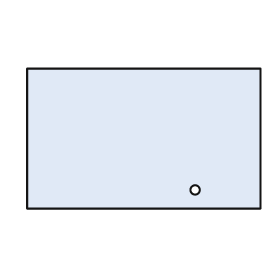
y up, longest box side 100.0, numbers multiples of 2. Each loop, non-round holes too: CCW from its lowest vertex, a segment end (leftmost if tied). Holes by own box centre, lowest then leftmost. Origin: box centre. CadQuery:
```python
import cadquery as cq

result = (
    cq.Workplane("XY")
    .moveTo(-50.0, -30.0)
    .lineTo(50.0, -30.0)
    .lineTo(50.0, 30.0)
    .lineTo(-50.0, 30.0)
    .close()
    .moveTo(22.0, -22.0)
    .circle(2.0)
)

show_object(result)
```